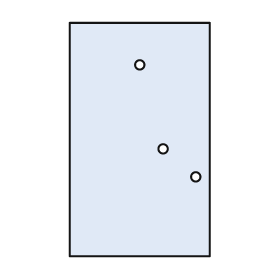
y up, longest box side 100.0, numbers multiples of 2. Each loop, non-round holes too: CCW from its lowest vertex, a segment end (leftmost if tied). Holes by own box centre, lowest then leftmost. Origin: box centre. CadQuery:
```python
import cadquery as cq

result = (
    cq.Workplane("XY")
    .moveTo(-30.0, -50.0)
    .lineTo(30.0, -50.0)
    .lineTo(30.0, 50.0)
    .lineTo(-30.0, 50.0)
    .close()
    .moveTo(24.0, -16.0)
    .circle(2.0)
    .moveTo(10.0, -4.0)
    .circle(2.0)
    .moveTo(0.0, 32.0)
    .circle(2.0)
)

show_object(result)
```